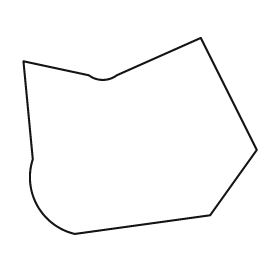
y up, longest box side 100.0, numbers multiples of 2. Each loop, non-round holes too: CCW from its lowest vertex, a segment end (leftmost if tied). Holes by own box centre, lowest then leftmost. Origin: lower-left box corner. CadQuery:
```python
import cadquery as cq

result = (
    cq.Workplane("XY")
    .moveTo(22.0, 0.0)
    .lineTo(80.0, 8.0)
    .lineTo(100.0, 36.0)
    .lineTo(76.0, 84.0)
    .lineTo(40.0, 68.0)
    .threePointArc((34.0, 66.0), (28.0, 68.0))
    .lineTo(0.0, 74.0)
    .lineTo(4.0, 32.0)
    .threePointArc((6.0, 12.0), (22.0, 0.0))
    .close()
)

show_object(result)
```